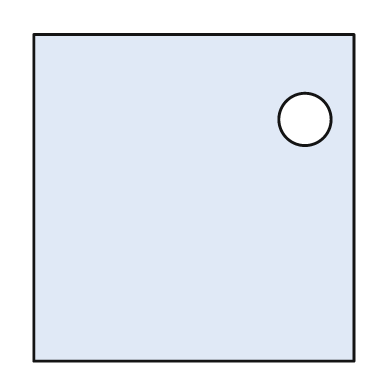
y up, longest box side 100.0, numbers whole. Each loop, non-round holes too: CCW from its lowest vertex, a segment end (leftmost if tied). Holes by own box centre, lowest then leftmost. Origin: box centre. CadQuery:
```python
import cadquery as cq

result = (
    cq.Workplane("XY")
    .moveTo(-49.0, -50.0)
    .lineTo(49.0, -50.0)
    .lineTo(49.0, 50.0)
    .lineTo(-49.0, 50.0)
    .close()
    .moveTo(34.0, 24.0)
    .circle(8.0)
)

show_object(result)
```